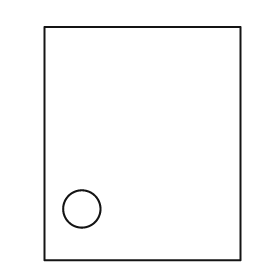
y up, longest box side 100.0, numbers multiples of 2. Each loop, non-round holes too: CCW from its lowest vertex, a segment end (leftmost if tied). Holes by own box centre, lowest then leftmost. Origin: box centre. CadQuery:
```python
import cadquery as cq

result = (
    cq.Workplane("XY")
    .moveTo(-42.0, -50.0)
    .lineTo(42.0, -50.0)
    .lineTo(42.0, 50.0)
    .lineTo(-42.0, 50.0)
    .close()
    .moveTo(-26.0, -28.0)
    .circle(8.0)
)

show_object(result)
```